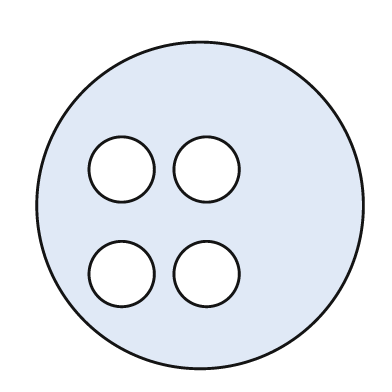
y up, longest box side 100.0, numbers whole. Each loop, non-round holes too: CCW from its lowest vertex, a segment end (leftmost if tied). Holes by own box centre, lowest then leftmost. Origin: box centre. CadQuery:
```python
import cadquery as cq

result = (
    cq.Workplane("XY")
    .moveTo(0.0, 0.0)
    .circle(50.0)
    .moveTo(-24.0, -21.0)
    .circle(10.0)
    .moveTo(2.0, -21.0)
    .circle(10.0)
    .moveTo(-24.0, 11.0)
    .circle(10.0)
    .moveTo(2.0, 11.0)
    .circle(10.0)
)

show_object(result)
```